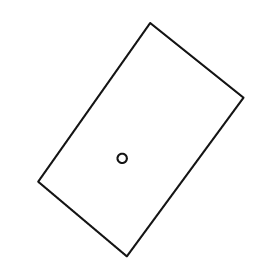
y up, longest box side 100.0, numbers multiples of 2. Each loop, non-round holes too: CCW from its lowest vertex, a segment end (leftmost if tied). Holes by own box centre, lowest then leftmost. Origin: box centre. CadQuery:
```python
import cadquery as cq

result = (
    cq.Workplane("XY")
    .moveTo(-6.0, -50.0)
    .lineTo(44.0, 18.0)
    .lineTo(4.0, 50.0)
    .lineTo(-44.0, -18.0)
    .close()
    .moveTo(-8.0, -8.0)
    .circle(2.0)
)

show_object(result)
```